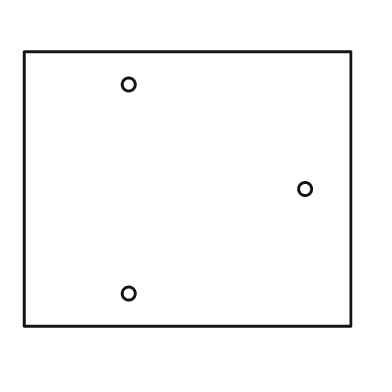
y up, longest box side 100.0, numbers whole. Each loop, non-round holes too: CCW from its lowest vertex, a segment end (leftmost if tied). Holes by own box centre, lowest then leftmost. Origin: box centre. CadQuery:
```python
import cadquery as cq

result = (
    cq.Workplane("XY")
    .moveTo(-50.0, -42.0)
    .lineTo(50.0, -42.0)
    .lineTo(50.0, 42.0)
    .lineTo(-50.0, 42.0)
    .close()
    .moveTo(-18.0, -32.0)
    .circle(2.0)
    .moveTo(36.0, 0.0)
    .circle(2.0)
    .moveTo(-18.0, 32.0)
    .circle(2.0)
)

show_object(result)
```